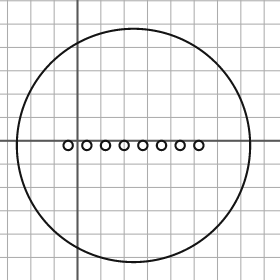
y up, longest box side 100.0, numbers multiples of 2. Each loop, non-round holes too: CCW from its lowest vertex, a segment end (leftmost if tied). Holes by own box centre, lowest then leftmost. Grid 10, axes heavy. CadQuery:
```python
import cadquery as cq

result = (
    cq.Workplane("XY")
    .moveTo(24.0, -2.0)
    .circle(50.0)
    .moveTo(-4.0, -2.0)
    .circle(2.0)
    .moveTo(4.0, -2.0)
    .circle(2.0)
    .moveTo(12.0, -2.0)
    .circle(2.0)
    .moveTo(20.0, -2.0)
    .circle(2.0)
    .moveTo(28.0, -2.0)
    .circle(2.0)
    .moveTo(36.0, -2.0)
    .circle(2.0)
    .moveTo(44.0, -2.0)
    .circle(2.0)
    .moveTo(52.0, -2.0)
    .circle(2.0)
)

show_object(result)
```